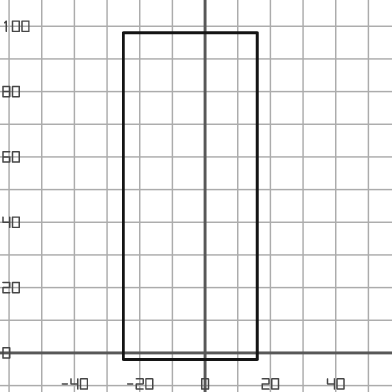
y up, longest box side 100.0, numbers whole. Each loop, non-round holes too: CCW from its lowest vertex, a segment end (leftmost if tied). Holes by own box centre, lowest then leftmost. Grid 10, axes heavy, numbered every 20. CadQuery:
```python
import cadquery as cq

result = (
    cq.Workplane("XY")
    .moveTo(-25.0, -2.0)
    .lineTo(16.0, -2.0)
    .lineTo(16.0, 98.0)
    .lineTo(-25.0, 98.0)
    .close()
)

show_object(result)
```